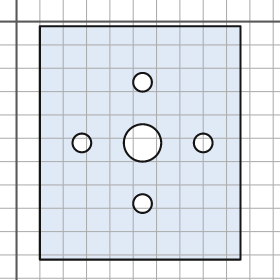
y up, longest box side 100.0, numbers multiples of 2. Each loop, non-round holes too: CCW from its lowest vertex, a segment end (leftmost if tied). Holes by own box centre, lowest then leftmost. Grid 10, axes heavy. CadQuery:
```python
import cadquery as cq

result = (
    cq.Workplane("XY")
    .moveTo(10.0, -102.0)
    .lineTo(96.0, -102.0)
    .lineTo(96.0, -2.0)
    .lineTo(10.0, -2.0)
    .close()
    .moveTo(54.0, -78.0)
    .circle(4.0)
    .moveTo(28.0, -52.0)
    .circle(4.0)
    .moveTo(54.0, -52.0)
    .circle(8.0)
    .moveTo(80.0, -52.0)
    .circle(4.0)
    .moveTo(54.0, -26.0)
    .circle(4.0)
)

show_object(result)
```